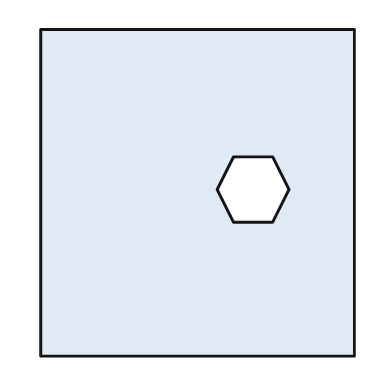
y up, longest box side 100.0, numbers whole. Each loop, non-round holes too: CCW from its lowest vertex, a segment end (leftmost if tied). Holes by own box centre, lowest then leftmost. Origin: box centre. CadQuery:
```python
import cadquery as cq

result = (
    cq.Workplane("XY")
    .moveTo(-48.0, -50.0)
    .lineTo(48.0, -50.0)
    .lineTo(48.0, 50.0)
    .lineTo(-48.0, 50.0)
    .close()
    .moveTo(11.0, -9.0)
    .lineTo(23.0, -9.0)
    .lineTo(28.0, 1.0)
    .lineTo(23.0, 11.0)
    .lineTo(11.0, 11.0)
    .lineTo(6.0, 1.0)
    .close()
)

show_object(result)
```